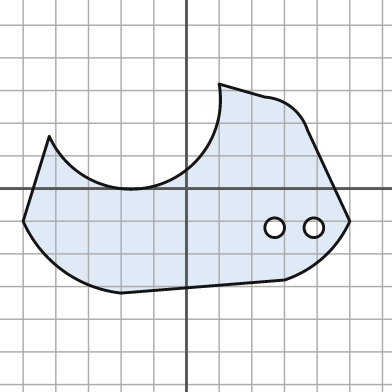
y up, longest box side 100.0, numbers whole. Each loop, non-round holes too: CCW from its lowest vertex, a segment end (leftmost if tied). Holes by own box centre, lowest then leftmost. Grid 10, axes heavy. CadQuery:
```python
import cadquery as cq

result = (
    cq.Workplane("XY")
    .moveTo(-20.0, -32.0)
    .lineTo(30.0, -28.0)
    .threePointArc((42.0, -21.0), (50.0, -10.0))
    .lineTo(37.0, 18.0)
    .threePointArc((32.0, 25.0), (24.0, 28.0))
    .lineTo(10.0, 32.0)
    .threePointArc((-9.0, 1.0), (-42.0, 16.0))
    .lineTo(-50.0, -10.0)
    .threePointArc((-38.0, -25.0), (-20.0, -32.0))
    .close()
    .moveTo(27.0, -12.0)
    .circle(3.0)
    .moveTo(39.0, -12.0)
    .circle(3.0)
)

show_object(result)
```